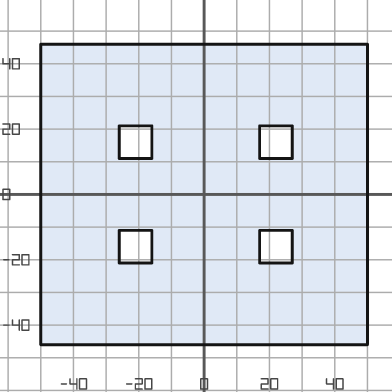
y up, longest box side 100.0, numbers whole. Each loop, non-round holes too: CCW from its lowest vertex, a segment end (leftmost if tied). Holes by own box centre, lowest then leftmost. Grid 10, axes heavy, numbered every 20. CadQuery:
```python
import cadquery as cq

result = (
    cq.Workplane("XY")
    .moveTo(-50.0, -46.0)
    .lineTo(50.0, -46.0)
    .lineTo(50.0, 46.0)
    .lineTo(-50.0, 46.0)
    .close()
    .moveTo(-26.0, -21.0)
    .lineTo(-16.0, -21.0)
    .lineTo(-16.0, -11.0)
    .lineTo(-26.0, -11.0)
    .close()
    .moveTo(17.0, -21.0)
    .lineTo(27.0, -21.0)
    .lineTo(27.0, -11.0)
    .lineTo(17.0, -11.0)
    .close()
    .moveTo(-26.0, 11.0)
    .lineTo(-16.0, 11.0)
    .lineTo(-16.0, 21.0)
    .lineTo(-26.0, 21.0)
    .close()
    .moveTo(17.0, 11.0)
    .lineTo(27.0, 11.0)
    .lineTo(27.0, 21.0)
    .lineTo(17.0, 21.0)
    .close()
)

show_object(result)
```